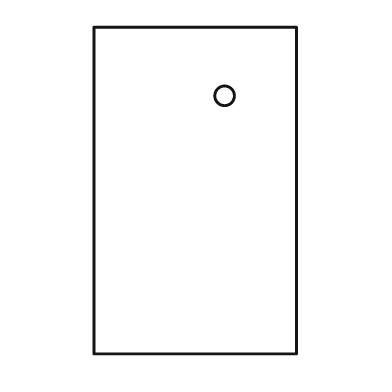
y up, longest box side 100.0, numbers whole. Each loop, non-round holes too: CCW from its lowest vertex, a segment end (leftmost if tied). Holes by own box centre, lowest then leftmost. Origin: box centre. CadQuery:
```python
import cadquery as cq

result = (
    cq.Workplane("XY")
    .moveTo(-31.0, -50.0)
    .lineTo(31.0, -50.0)
    .lineTo(31.0, 50.0)
    .lineTo(-31.0, 50.0)
    .close()
    .moveTo(9.0, 29.0)
    .circle(3.0)
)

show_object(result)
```